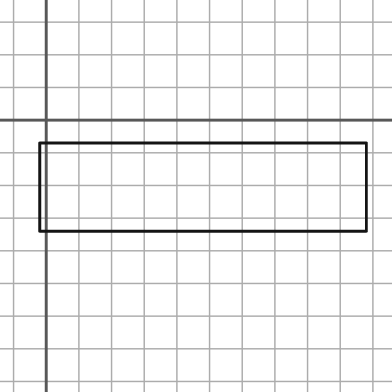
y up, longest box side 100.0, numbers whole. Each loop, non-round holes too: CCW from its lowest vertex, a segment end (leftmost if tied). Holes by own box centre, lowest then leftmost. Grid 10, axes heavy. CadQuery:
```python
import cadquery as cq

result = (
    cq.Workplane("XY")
    .moveTo(-2.0, -34.0)
    .lineTo(98.0, -34.0)
    .lineTo(98.0, -7.0)
    .lineTo(-2.0, -7.0)
    .close()
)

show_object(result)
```